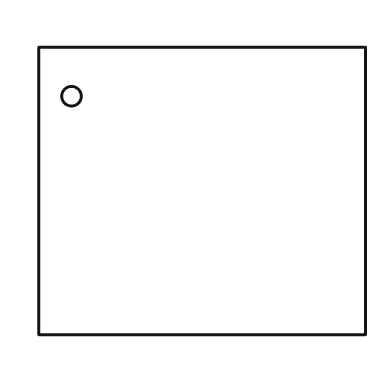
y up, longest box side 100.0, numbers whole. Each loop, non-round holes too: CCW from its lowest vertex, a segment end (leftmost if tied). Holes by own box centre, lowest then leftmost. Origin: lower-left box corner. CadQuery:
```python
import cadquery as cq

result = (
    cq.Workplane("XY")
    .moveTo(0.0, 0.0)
    .lineTo(100.0, 0.0)
    .lineTo(100.0, 88.0)
    .lineTo(0.0, 88.0)
    .close()
    .moveTo(10.0, 73.0)
    .circle(3.0)
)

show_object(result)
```